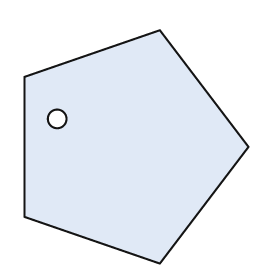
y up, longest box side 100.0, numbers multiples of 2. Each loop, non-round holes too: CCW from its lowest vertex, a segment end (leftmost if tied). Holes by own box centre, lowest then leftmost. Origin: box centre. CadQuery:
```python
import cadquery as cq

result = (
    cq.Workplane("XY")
    .moveTo(10.0, -50.0)
    .lineTo(48.0, 0.0)
    .lineTo(10.0, 50.0)
    .lineTo(-48.0, 30.0)
    .lineTo(-48.0, -30.0)
    .close()
    .moveTo(-34.0, 12.0)
    .circle(4.0)
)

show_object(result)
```